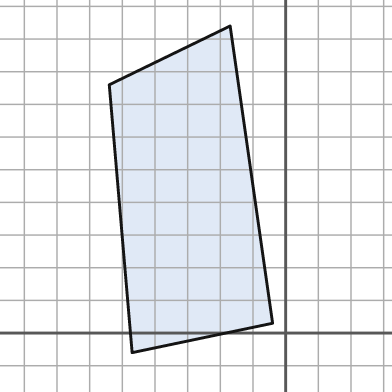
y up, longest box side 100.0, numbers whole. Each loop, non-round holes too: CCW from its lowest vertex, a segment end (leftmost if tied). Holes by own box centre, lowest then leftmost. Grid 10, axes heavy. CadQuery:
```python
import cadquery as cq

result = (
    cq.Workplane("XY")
    .moveTo(-47.0, -6.0)
    .lineTo(-4.0, 3.0)
    .lineTo(-17.0, 94.0)
    .lineTo(-54.0, 76.0)
    .close()
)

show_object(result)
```